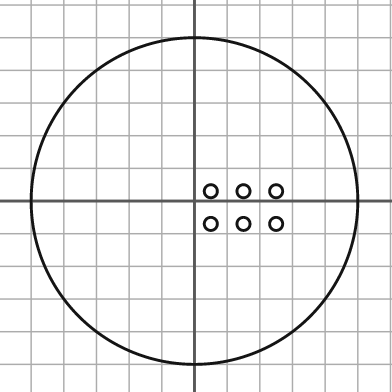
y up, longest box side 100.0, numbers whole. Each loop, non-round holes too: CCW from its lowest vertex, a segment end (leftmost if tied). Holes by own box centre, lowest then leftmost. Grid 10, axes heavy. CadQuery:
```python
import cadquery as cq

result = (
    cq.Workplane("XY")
    .moveTo(0.0, 0.0)
    .circle(50.0)
    .moveTo(5.0, -7.0)
    .circle(2.0)
    .moveTo(15.0, -7.0)
    .circle(2.0)
    .moveTo(25.0, -7.0)
    .circle(2.0)
    .moveTo(5.0, 3.0)
    .circle(2.0)
    .moveTo(15.0, 3.0)
    .circle(2.0)
    .moveTo(25.0, 3.0)
    .circle(2.0)
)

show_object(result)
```